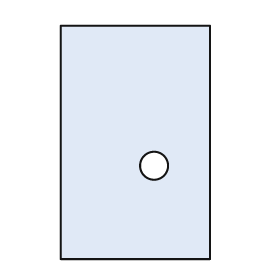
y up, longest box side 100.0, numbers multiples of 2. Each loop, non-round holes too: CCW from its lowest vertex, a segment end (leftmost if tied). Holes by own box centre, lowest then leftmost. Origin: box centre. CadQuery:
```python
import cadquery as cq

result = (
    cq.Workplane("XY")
    .moveTo(-32.0, -50.0)
    .lineTo(32.0, -50.0)
    .lineTo(32.0, 50.0)
    .lineTo(-32.0, 50.0)
    .close()
    .moveTo(8.0, -10.0)
    .circle(6.0)
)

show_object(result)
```